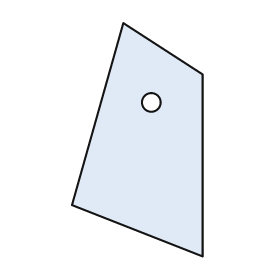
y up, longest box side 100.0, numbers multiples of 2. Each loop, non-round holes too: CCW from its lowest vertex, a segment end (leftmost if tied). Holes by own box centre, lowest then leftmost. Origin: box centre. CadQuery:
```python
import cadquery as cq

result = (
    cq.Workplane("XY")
    .moveTo(28.0, -50.0)
    .lineTo(28.0, 28.0)
    .lineTo(-6.0, 50.0)
    .lineTo(-28.0, -28.0)
    .close()
    .moveTo(6.0, 16.0)
    .circle(4.0)
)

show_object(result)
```